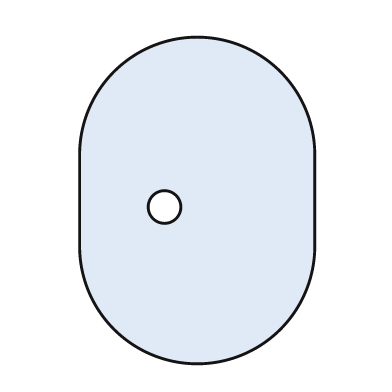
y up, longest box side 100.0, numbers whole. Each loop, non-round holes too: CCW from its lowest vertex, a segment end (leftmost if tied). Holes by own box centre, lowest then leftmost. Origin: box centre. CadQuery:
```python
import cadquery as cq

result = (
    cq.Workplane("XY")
    .moveTo(-36.0, -14.0)
    .threePointArc((0.0, -50.0), (36.0, -14.0))
    .lineTo(36.0, 14.0)
    .threePointArc((0.0, 50.0), (-36.0, 14.0))
    .close()
    .moveTo(-10.0, -2.0)
    .circle(5.0)
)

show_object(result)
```